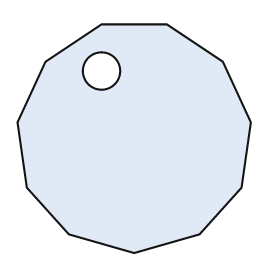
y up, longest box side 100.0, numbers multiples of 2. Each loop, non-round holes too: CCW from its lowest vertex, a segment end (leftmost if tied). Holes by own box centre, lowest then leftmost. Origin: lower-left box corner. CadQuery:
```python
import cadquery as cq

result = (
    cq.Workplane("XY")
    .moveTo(50.0, 0.0)
    .lineTo(78.0, 8.0)
    .lineTo(96.0, 28.0)
    .lineTo(100.0, 56.0)
    .lineTo(88.0, 82.0)
    .lineTo(64.0, 98.0)
    .lineTo(36.0, 98.0)
    .lineTo(12.0, 82.0)
    .lineTo(0.0, 56.0)
    .lineTo(4.0, 28.0)
    .lineTo(22.0, 8.0)
    .close()
    .moveTo(36.0, 78.0)
    .circle(8.0)
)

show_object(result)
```